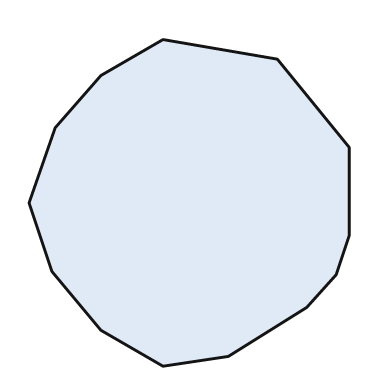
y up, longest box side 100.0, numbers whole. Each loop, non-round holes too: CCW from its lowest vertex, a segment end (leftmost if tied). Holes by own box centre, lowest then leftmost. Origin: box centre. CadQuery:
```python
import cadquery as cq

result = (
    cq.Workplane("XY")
    .moveTo(-8.0, -50.0)
    .lineTo(12.0, -47.0)
    .lineTo(36.0, -32.0)
    .lineTo(45.0, -22.0)
    .lineTo(49.0, -10.0)
    .lineTo(49.0, 17.0)
    .lineTo(27.0, 44.0)
    .lineTo(-8.0, 50.0)
    .lineTo(-27.0, 39.0)
    .lineTo(-41.0, 23.0)
    .lineTo(-49.0, 0.0)
    .lineTo(-42.0, -21.0)
    .lineTo(-27.0, -39.0)
    .close()
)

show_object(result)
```